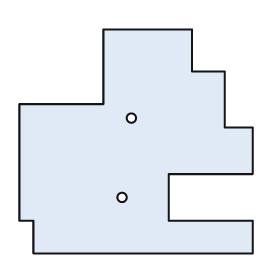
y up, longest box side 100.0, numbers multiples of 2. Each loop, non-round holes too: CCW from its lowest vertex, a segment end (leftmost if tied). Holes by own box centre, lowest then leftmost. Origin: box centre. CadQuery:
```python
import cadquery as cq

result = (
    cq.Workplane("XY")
    .moveTo(-44.0, -48.0)
    .lineTo(50.0, -48.0)
    .lineTo(50.0, -34.0)
    .lineTo(14.0, -34.0)
    .lineTo(14.0, -14.0)
    .lineTo(50.0, -14.0)
    .lineTo(50.0, 6.0)
    .lineTo(38.0, 6.0)
    .lineTo(38.0, 30.0)
    .lineTo(24.0, 30.0)
    .lineTo(24.0, 48.0)
    .lineTo(-14.0, 48.0)
    .lineTo(-14.0, 16.0)
    .lineTo(-50.0, 16.0)
    .lineTo(-50.0, -34.0)
    .lineTo(-44.0, -34.0)
    .close()
    .moveTo(-6.0, -24.0)
    .circle(2.0)
    .moveTo(-2.0, 10.0)
    .circle(2.0)
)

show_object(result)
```